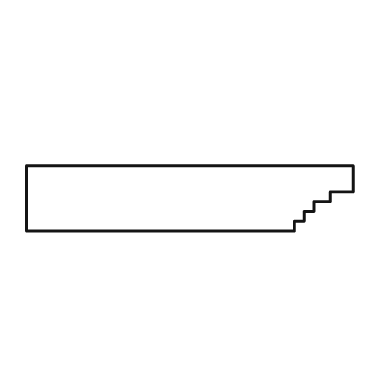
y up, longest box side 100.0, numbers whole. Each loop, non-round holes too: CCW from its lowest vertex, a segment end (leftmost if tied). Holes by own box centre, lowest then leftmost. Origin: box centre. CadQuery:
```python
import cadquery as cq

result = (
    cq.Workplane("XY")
    .moveTo(-50.0, -10.0)
    .lineTo(32.0, -10.0)
    .lineTo(32.0, -7.0)
    .lineTo(35.0, -7.0)
    .lineTo(35.0, -4.0)
    .lineTo(38.0, -4.0)
    .lineTo(38.0, -1.0)
    .lineTo(43.0, -1.0)
    .lineTo(43.0, 2.0)
    .lineTo(50.0, 2.0)
    .lineTo(50.0, 10.0)
    .lineTo(-50.0, 10.0)
    .close()
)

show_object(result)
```